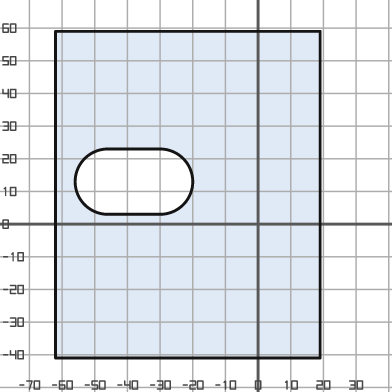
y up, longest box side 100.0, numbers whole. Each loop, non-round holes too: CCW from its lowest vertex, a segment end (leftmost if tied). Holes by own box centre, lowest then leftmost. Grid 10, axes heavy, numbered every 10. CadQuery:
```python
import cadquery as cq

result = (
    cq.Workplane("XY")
    .moveTo(-62.0, -41.0)
    .lineTo(19.0, -41.0)
    .lineTo(19.0, 59.0)
    .lineTo(-62.0, 59.0)
    .close()
    .moveTo(-46.0, 3.0)
    .lineTo(-30.0, 3.0)
    .threePointArc((-20.0, 13.0), (-30.0, 23.0))
    .lineTo(-46.0, 23.0)
    .threePointArc((-56.0, 13.0), (-46.0, 3.0))
    .close()
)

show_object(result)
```